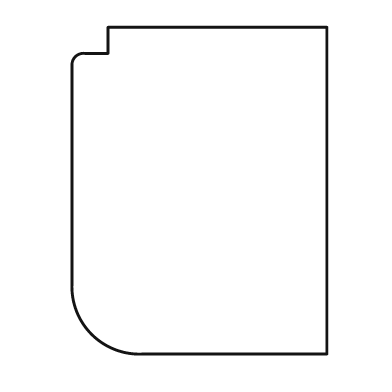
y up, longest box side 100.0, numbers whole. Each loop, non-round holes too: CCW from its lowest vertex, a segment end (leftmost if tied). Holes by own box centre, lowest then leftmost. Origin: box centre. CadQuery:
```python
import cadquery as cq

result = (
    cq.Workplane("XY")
    .moveTo(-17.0, -50.0)
    .lineTo(39.0, -50.0)
    .lineTo(39.0, 50.0)
    .lineTo(-28.0, 50.0)
    .lineTo(-28.0, 42.0)
    .lineTo(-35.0, 42.0)
    .threePointArc((-38.0, 41.0), (-39.0, 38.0))
    .lineTo(-39.0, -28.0)
    .threePointArc((-33.0, -44.0), (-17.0, -50.0))
    .close()
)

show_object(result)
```